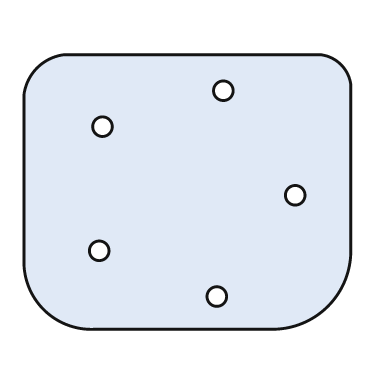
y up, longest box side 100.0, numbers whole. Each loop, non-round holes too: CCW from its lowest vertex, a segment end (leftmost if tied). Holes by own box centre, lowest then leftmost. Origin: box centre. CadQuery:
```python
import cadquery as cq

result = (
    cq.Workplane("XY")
    .moveTo(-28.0, -42.0)
    .lineTo(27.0, -42.0)
    .threePointArc((43.0, -35.0), (50.0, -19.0))
    .lineTo(50.0, 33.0)
    .threePointArc((47.0, 39.0), (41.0, 42.0))
    .lineTo(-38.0, 42.0)
    .threePointArc((-46.0, 38.0), (-50.0, 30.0))
    .lineTo(-50.0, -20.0)
    .threePointArc((-44.0, -36.0), (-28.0, -42.0))
    .close()
    .moveTo(9.0, -32.0)
    .circle(3.0)
    .moveTo(-27.0, -18.0)
    .circle(3.0)
    .moveTo(33.0, -1.0)
    .circle(3.0)
    .moveTo(-26.0, 20.0)
    .circle(3.0)
    .moveTo(11.0, 31.0)
    .circle(3.0)
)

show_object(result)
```